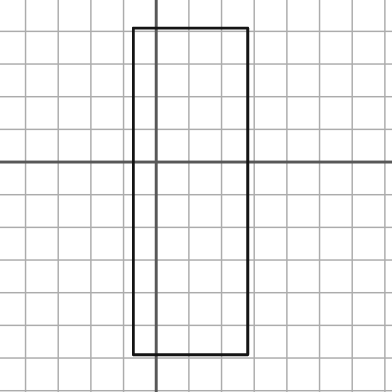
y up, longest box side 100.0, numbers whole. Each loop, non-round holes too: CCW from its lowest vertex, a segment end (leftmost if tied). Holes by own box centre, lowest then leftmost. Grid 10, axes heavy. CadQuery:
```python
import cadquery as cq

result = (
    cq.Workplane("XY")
    .moveTo(-7.0, -59.0)
    .lineTo(28.0, -59.0)
    .lineTo(28.0, 41.0)
    .lineTo(-7.0, 41.0)
    .close()
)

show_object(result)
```